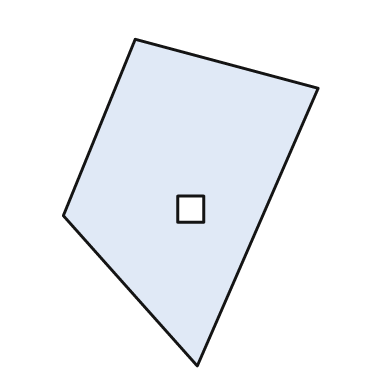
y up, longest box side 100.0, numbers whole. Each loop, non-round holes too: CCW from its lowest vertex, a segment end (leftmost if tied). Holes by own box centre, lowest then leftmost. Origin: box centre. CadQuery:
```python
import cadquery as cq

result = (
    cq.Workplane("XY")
    .moveTo(2.0, -50.0)
    .lineTo(39.0, 35.0)
    .lineTo(-17.0, 50.0)
    .lineTo(-39.0, -4.0)
    .close()
    .moveTo(-4.0, -6.0)
    .lineTo(4.0, -6.0)
    .lineTo(4.0, 2.0)
    .lineTo(-4.0, 2.0)
    .close()
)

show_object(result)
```